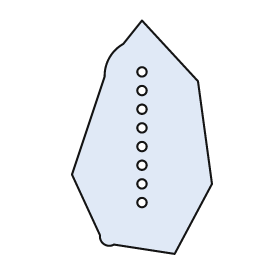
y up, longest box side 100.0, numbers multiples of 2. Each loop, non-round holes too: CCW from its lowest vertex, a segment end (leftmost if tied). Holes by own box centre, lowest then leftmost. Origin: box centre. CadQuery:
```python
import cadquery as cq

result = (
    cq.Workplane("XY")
    .moveTo(14.0, -50.0)
    .lineTo(30.0, -20.0)
    .lineTo(24.0, 24.0)
    .lineTo(0.0, 50.0)
    .lineTo(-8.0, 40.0)
    .threePointArc((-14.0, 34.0), (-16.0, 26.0))
    .lineTo(-30.0, -16.0)
    .lineTo(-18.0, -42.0)
    .threePointArc((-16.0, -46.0), (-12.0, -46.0))
    .close()
    .moveTo(0.0, -28.0)
    .circle(2.0)
    .moveTo(0.0, -20.0)
    .circle(2.0)
    .moveTo(0.0, -12.0)
    .circle(2.0)
    .moveTo(0.0, -4.0)
    .circle(2.0)
    .moveTo(0.0, 4.0)
    .circle(2.0)
    .moveTo(0.0, 12.0)
    .circle(2.0)
    .moveTo(0.0, 20.0)
    .circle(2.0)
    .moveTo(0.0, 28.0)
    .circle(2.0)
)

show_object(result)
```